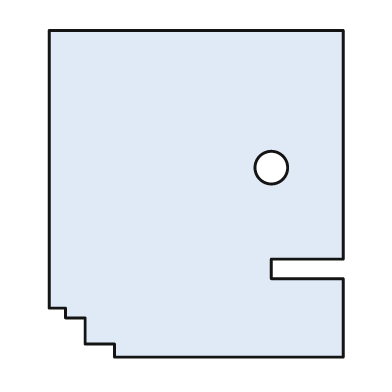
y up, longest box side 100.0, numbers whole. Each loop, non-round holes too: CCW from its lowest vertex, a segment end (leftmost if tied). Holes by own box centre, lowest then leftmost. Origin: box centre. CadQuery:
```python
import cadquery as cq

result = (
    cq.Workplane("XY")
    .moveTo(-25.0, -50.0)
    .lineTo(45.0, -50.0)
    .lineTo(45.0, -26.0)
    .lineTo(23.0, -26.0)
    .lineTo(23.0, -20.0)
    .lineTo(45.0, -20.0)
    .lineTo(45.0, 50.0)
    .lineTo(-45.0, 50.0)
    .lineTo(-45.0, -35.0)
    .lineTo(-40.0, -35.0)
    .lineTo(-40.0, -38.0)
    .lineTo(-34.0, -38.0)
    .lineTo(-34.0, -46.0)
    .lineTo(-25.0, -46.0)
    .close()
    .moveTo(23.0, 8.0)
    .circle(5.0)
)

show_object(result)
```